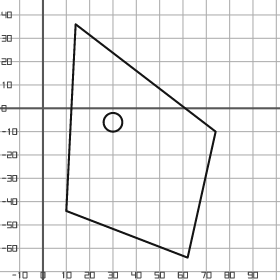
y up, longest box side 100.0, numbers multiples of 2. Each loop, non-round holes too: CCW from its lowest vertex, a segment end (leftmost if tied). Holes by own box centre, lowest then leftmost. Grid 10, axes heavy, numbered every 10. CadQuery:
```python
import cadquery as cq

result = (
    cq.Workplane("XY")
    .moveTo(62.0, -64.0)
    .lineTo(74.0, -10.0)
    .lineTo(14.0, 36.0)
    .lineTo(10.0, -44.0)
    .close()
    .moveTo(30.0, -6.0)
    .circle(4.0)
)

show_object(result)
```